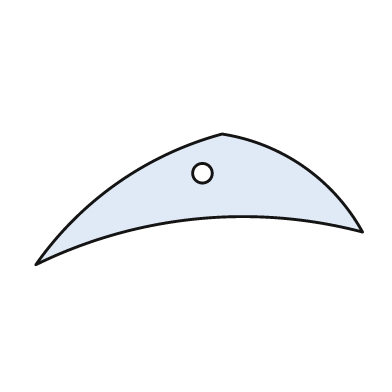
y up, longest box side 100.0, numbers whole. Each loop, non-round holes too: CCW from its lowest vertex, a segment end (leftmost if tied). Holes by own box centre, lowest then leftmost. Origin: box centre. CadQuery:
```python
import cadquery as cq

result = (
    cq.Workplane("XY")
    .moveTo(-50.0, -20.0)
    .threePointArc((-1.0, -6.0), (50.0, -10.0))
    .threePointArc((32.0, 10.0), (7.0, 20.0))
    .threePointArc((-25.0, 5.0), (-50.0, -20.0))
    .close()
    .moveTo(1.0, 8.0)
    .circle(3.0)
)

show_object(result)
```